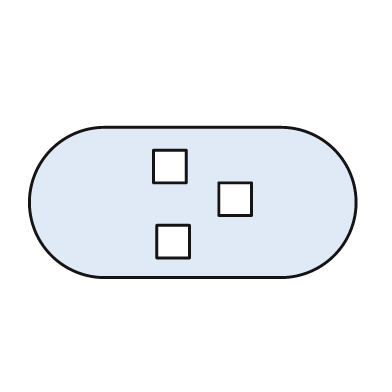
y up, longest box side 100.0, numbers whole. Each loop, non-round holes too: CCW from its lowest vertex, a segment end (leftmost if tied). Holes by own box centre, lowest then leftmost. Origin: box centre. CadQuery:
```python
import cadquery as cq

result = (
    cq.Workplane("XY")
    .moveTo(-27.0, -23.0)
    .lineTo(27.0, -23.0)
    .threePointArc((50.0, 0.0), (27.0, 23.0))
    .lineTo(-27.0, 23.0)
    .threePointArc((-50.0, 0.0), (-27.0, -23.0))
    .close()
    .moveTo(-11.0, -17.0)
    .lineTo(-1.0, -17.0)
    .lineTo(-1.0, -7.0)
    .lineTo(-11.0, -7.0)
    .close()
    .moveTo(8.0, -4.0)
    .lineTo(18.0, -4.0)
    .lineTo(18.0, 6.0)
    .lineTo(8.0, 6.0)
    .close()
    .moveTo(-12.0, 6.0)
    .lineTo(-2.0, 6.0)
    .lineTo(-2.0, 16.0)
    .lineTo(-12.0, 16.0)
    .close()
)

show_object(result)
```